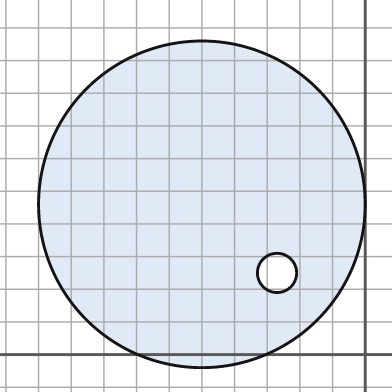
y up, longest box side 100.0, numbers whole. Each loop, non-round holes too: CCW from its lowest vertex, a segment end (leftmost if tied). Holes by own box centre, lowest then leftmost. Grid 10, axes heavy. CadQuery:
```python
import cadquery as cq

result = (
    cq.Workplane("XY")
    .moveTo(-50.0, 46.0)
    .circle(50.0)
    .moveTo(-27.0, 25.0)
    .circle(6.0)
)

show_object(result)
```